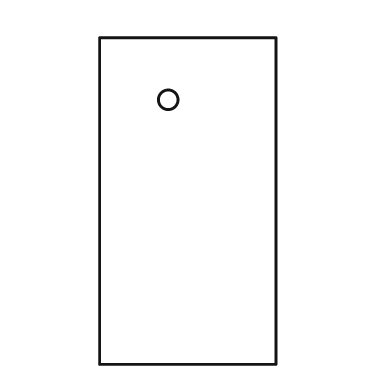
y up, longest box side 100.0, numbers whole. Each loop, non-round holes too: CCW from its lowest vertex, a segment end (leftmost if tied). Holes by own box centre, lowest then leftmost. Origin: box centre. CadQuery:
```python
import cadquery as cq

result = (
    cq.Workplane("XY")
    .moveTo(-27.0, -50.0)
    .lineTo(27.0, -50.0)
    .lineTo(27.0, 50.0)
    .lineTo(-27.0, 50.0)
    .close()
    .moveTo(-6.0, 31.0)
    .circle(3.0)
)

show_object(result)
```